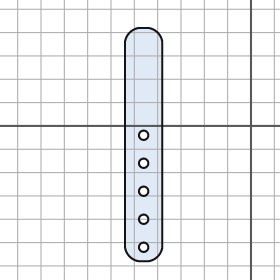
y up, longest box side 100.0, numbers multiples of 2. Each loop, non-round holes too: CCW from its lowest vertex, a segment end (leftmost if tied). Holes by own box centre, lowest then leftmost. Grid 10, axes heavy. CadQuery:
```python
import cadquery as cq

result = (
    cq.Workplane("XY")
    .moveTo(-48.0, -58.0)
    .lineTo(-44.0, -58.0)
    .threePointArc((-40.0, -56.0), (-38.0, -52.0))
    .lineTo(-38.0, 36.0)
    .threePointArc((-40.0, 40.0), (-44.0, 42.0))
    .lineTo(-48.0, 42.0)
    .threePointArc((-52.0, 40.0), (-54.0, 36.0))
    .lineTo(-54.0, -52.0)
    .threePointArc((-52.0, -56.0), (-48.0, -58.0))
    .close()
    .moveTo(-46.0, -52.0)
    .circle(2.0)
    .moveTo(-46.0, -40.0)
    .circle(2.0)
    .moveTo(-46.0, -28.0)
    .circle(2.0)
    .moveTo(-46.0, -16.0)
    .circle(2.0)
    .moveTo(-46.0, -4.0)
    .circle(2.0)
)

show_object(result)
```